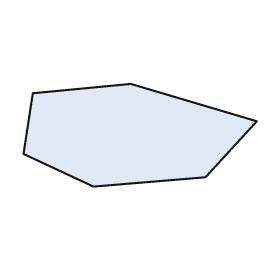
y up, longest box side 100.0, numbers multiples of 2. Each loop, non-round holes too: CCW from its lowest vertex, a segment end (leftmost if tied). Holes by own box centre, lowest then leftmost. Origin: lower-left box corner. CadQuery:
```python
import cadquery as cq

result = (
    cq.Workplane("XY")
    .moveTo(30.0, 0.0)
    .lineTo(78.0, 4.0)
    .lineTo(100.0, 28.0)
    .lineTo(46.0, 44.0)
    .lineTo(4.0, 40.0)
    .lineTo(0.0, 14.0)
    .close()
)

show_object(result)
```